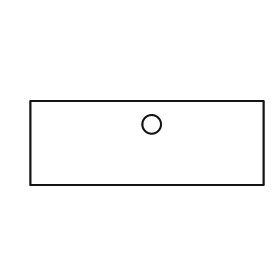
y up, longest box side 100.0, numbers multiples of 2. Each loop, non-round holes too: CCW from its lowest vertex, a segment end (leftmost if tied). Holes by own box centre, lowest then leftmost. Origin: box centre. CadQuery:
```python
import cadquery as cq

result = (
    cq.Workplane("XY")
    .moveTo(-50.0, -18.0)
    .lineTo(50.0, -18.0)
    .lineTo(50.0, 18.0)
    .lineTo(-50.0, 18.0)
    .close()
    .moveTo(2.0, 8.0)
    .circle(4.0)
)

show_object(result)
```